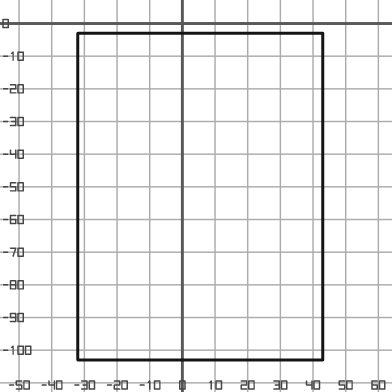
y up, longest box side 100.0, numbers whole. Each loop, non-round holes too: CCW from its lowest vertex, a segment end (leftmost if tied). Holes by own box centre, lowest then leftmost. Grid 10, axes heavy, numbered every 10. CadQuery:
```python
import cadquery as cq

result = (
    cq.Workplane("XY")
    .moveTo(-32.0, -103.0)
    .lineTo(43.0, -103.0)
    .lineTo(43.0, -3.0)
    .lineTo(-32.0, -3.0)
    .close()
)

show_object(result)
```